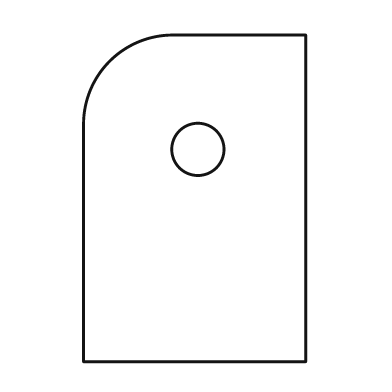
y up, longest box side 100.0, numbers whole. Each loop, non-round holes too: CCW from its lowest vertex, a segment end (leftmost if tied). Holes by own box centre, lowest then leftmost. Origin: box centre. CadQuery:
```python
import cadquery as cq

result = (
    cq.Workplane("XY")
    .moveTo(-34.0, -50.0)
    .lineTo(34.0, -50.0)
    .lineTo(34.0, 50.0)
    .lineTo(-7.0, 50.0)
    .threePointArc((-26.0, 42.0), (-34.0, 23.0))
    .close()
    .moveTo(1.0, 15.0)
    .circle(8.0)
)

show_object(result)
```